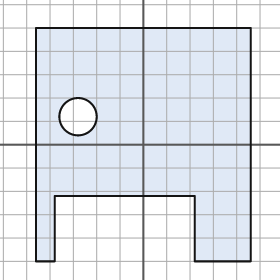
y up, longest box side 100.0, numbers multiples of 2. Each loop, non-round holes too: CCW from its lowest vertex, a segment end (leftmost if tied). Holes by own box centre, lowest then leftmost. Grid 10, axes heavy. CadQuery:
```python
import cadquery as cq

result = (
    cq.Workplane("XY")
    .moveTo(-46.0, -50.0)
    .lineTo(-38.0, -50.0)
    .lineTo(-38.0, -22.0)
    .lineTo(22.0, -22.0)
    .lineTo(22.0, -50.0)
    .lineTo(46.0, -50.0)
    .lineTo(46.0, 50.0)
    .lineTo(-46.0, 50.0)
    .close()
    .moveTo(-28.0, 12.0)
    .circle(8.0)
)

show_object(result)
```